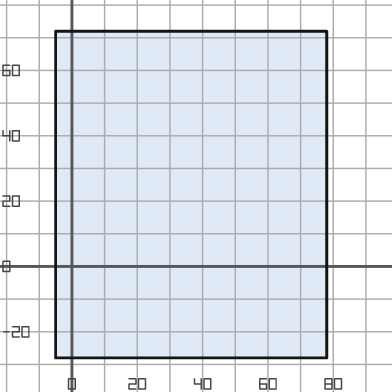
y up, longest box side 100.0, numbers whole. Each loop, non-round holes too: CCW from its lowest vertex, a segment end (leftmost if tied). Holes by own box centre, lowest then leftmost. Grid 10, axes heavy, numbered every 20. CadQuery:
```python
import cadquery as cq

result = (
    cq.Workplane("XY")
    .moveTo(-5.0, -28.0)
    .lineTo(78.0, -28.0)
    .lineTo(78.0, 72.0)
    .lineTo(-5.0, 72.0)
    .close()
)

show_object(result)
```